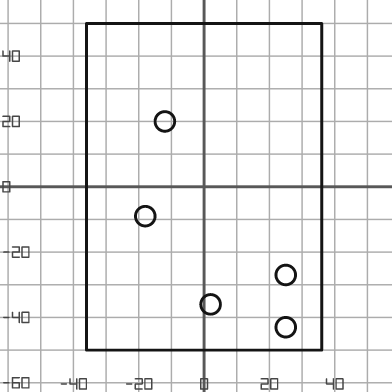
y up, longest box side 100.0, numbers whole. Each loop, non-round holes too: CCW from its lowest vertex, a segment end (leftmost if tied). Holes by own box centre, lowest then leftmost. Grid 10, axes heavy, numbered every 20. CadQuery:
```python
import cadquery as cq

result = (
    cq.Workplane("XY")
    .moveTo(-36.0, -50.0)
    .lineTo(36.0, -50.0)
    .lineTo(36.0, 50.0)
    .lineTo(-36.0, 50.0)
    .close()
    .moveTo(25.0, -43.0)
    .circle(3.0)
    .moveTo(2.0, -36.0)
    .circle(3.0)
    .moveTo(25.0, -27.0)
    .circle(3.0)
    .moveTo(-18.0, -9.0)
    .circle(3.0)
    .moveTo(-12.0, 20.0)
    .circle(3.0)
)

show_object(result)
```